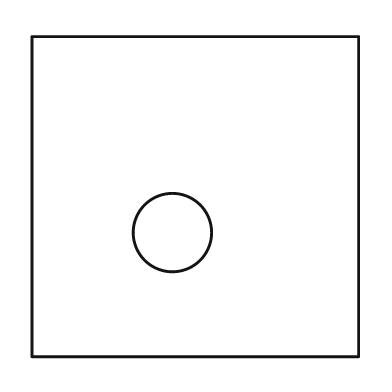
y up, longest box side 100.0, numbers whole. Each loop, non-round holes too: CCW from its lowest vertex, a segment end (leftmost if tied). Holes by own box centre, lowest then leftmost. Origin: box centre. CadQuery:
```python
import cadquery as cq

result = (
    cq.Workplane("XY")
    .moveTo(-50.0, -49.0)
    .lineTo(50.0, -49.0)
    .lineTo(50.0, 49.0)
    .lineTo(-50.0, 49.0)
    .close()
    .moveTo(-7.0, -11.0)
    .circle(12.0)
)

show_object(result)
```